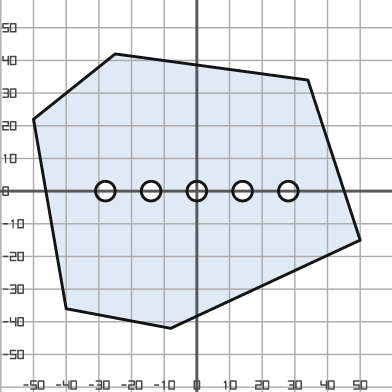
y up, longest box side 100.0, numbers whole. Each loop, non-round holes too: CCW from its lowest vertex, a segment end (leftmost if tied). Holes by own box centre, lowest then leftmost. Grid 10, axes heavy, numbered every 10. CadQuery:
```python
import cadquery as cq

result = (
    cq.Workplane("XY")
    .moveTo(-8.0, -42.0)
    .lineTo(50.0, -15.0)
    .lineTo(34.0, 34.0)
    .lineTo(-25.0, 42.0)
    .lineTo(-50.0, 22.0)
    .lineTo(-40.0, -36.0)
    .close()
    .moveTo(-28.0, 0.0)
    .circle(3.0)
    .moveTo(-14.0, 0.0)
    .circle(3.0)
    .moveTo(0.0, 0.0)
    .circle(3.0)
    .moveTo(14.0, 0.0)
    .circle(3.0)
    .moveTo(28.0, 0.0)
    .circle(3.0)
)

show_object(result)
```